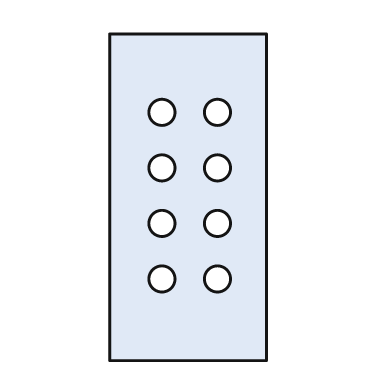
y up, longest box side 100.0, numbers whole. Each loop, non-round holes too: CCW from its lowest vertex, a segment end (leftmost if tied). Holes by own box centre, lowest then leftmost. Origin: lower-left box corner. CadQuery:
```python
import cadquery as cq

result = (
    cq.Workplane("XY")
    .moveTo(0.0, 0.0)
    .lineTo(48.0, 0.0)
    .lineTo(48.0, 100.0)
    .lineTo(0.0, 100.0)
    .close()
    .moveTo(16.0, 25.0)
    .circle(4.0)
    .moveTo(33.0, 25.0)
    .circle(4.0)
    .moveTo(16.0, 42.0)
    .circle(4.0)
    .moveTo(33.0, 42.0)
    .circle(4.0)
    .moveTo(16.0, 59.0)
    .circle(4.0)
    .moveTo(33.0, 59.0)
    .circle(4.0)
    .moveTo(16.0, 76.0)
    .circle(4.0)
    .moveTo(33.0, 76.0)
    .circle(4.0)
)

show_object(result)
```